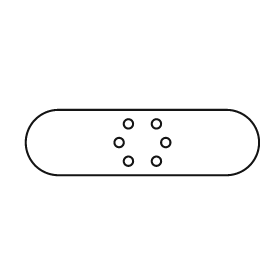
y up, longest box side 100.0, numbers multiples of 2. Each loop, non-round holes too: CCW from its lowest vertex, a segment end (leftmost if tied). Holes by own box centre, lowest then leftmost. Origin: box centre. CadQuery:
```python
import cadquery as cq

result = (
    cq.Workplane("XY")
    .moveTo(-36.0, -14.0)
    .lineTo(36.0, -14.0)
    .threePointArc((50.0, 0.0), (36.0, 14.0))
    .lineTo(-36.0, 14.0)
    .threePointArc((-50.0, 0.0), (-36.0, -14.0))
    .close()
    .moveTo(-6.0, -8.0)
    .circle(2.0)
    .moveTo(6.0, -8.0)
    .circle(2.0)
    .moveTo(-10.0, 0.0)
    .circle(2.0)
    .moveTo(10.0, 0.0)
    .circle(2.0)
    .moveTo(-6.0, 8.0)
    .circle(2.0)
    .moveTo(6.0, 8.0)
    .circle(2.0)
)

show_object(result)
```